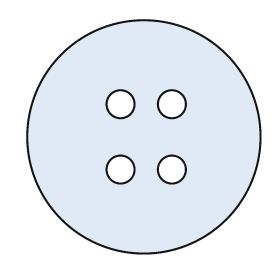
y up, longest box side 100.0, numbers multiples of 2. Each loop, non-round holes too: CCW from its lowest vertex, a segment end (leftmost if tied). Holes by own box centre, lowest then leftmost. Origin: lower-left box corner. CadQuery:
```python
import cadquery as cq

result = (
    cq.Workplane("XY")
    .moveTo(50.0, 50.0)
    .circle(50.0)
    .moveTo(40.0, 36.0)
    .circle(6.0)
    .moveTo(62.0, 36.0)
    .circle(6.0)
    .moveTo(40.0, 64.0)
    .circle(6.0)
    .moveTo(62.0, 64.0)
    .circle(6.0)
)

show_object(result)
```